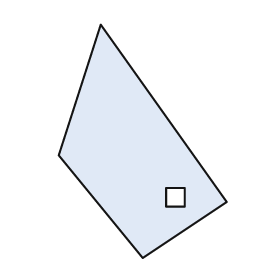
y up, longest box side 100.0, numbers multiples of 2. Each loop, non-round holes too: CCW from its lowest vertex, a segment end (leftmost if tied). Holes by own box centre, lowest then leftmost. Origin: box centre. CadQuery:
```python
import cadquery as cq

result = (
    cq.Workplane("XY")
    .moveTo(0.0, -50.0)
    .lineTo(36.0, -26.0)
    .lineTo(-18.0, 50.0)
    .lineTo(-36.0, -6.0)
    .close()
    .moveTo(10.0, -28.0)
    .lineTo(18.0, -28.0)
    .lineTo(18.0, -20.0)
    .lineTo(10.0, -20.0)
    .close()
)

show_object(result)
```